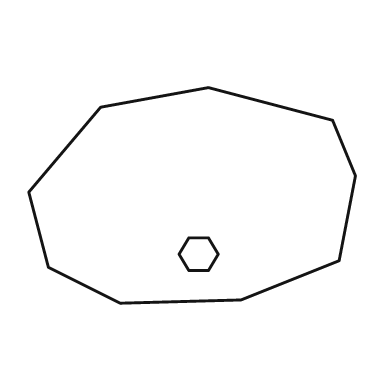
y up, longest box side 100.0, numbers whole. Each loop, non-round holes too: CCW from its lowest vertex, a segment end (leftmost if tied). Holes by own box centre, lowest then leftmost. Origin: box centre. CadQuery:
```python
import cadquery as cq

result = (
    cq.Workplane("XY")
    .moveTo(-22.0, -33.0)
    .lineTo(15.0, -32.0)
    .lineTo(45.0, -20.0)
    .lineTo(50.0, 6.0)
    .lineTo(43.0, 23.0)
    .lineTo(5.0, 33.0)
    .lineTo(-28.0, 27.0)
    .lineTo(-50.0, 1.0)
    .lineTo(-44.0, -22.0)
    .close()
    .moveTo(-1.0, -23.0)
    .lineTo(5.0, -23.0)
    .lineTo(8.0, -18.0)
    .lineTo(5.0, -13.0)
    .lineTo(-1.0, -13.0)
    .lineTo(-4.0, -18.0)
    .close()
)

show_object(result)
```